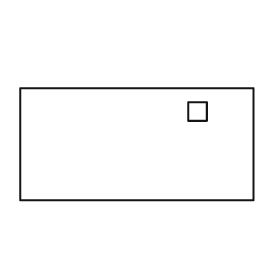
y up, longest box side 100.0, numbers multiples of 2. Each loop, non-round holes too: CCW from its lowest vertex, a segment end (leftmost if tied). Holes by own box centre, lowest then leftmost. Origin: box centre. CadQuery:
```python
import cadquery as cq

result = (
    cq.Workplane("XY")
    .moveTo(-50.0, -24.0)
    .lineTo(50.0, -24.0)
    .lineTo(50.0, 24.0)
    .lineTo(-50.0, 24.0)
    .close()
    .moveTo(22.0, 10.0)
    .lineTo(30.0, 10.0)
    .lineTo(30.0, 18.0)
    .lineTo(22.0, 18.0)
    .close()
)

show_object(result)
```